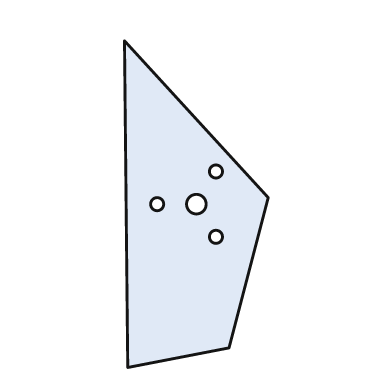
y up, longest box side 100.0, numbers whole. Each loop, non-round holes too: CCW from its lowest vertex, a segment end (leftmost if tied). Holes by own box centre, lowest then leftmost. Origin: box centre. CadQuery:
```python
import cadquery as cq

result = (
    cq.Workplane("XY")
    .moveTo(-21.0, -50.0)
    .lineTo(10.0, -44.0)
    .lineTo(22.0, 2.0)
    .lineTo(-22.0, 50.0)
    .close()
    .moveTo(6.0, -10.0)
    .circle(2.0)
    .moveTo(-12.0, 0.0)
    .circle(2.0)
    .moveTo(0.0, 0.0)
    .circle(3.0)
    .moveTo(6.0, 10.0)
    .circle(2.0)
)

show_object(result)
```